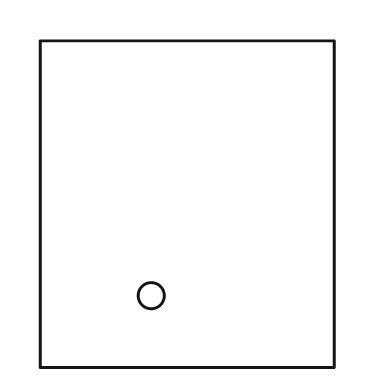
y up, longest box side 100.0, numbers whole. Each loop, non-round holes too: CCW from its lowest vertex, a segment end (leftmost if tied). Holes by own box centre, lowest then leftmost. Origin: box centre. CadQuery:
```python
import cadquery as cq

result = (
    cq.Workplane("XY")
    .moveTo(-45.0, -50.0)
    .lineTo(45.0, -50.0)
    .lineTo(45.0, 50.0)
    .lineTo(-45.0, 50.0)
    .close()
    .moveTo(-11.0, -28.0)
    .circle(4.0)
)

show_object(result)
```